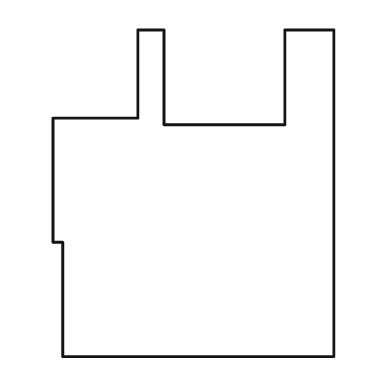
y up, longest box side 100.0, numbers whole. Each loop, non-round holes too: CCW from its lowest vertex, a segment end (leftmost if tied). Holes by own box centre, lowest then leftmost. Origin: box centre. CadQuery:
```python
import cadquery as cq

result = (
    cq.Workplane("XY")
    .moveTo(-40.0, -50.0)
    .lineTo(43.0, -50.0)
    .lineTo(43.0, 50.0)
    .lineTo(28.0, 50.0)
    .lineTo(28.0, 21.0)
    .lineTo(-9.0, 21.0)
    .lineTo(-9.0, 50.0)
    .lineTo(-17.0, 50.0)
    .lineTo(-17.0, 23.0)
    .lineTo(-43.0, 23.0)
    .lineTo(-43.0, -15.0)
    .lineTo(-40.0, -15.0)
    .close()
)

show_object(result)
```